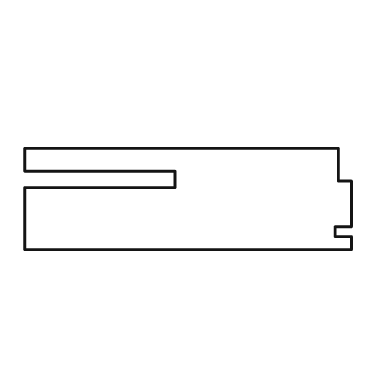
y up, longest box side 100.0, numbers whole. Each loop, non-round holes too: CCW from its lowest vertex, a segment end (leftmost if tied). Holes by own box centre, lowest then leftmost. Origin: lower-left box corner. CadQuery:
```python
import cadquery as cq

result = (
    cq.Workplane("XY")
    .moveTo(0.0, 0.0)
    .lineTo(100.0, 0.0)
    .lineTo(100.0, 4.0)
    .lineTo(95.0, 4.0)
    .lineTo(95.0, 7.0)
    .lineTo(100.0, 7.0)
    .lineTo(100.0, 21.0)
    .lineTo(96.0, 21.0)
    .lineTo(96.0, 31.0)
    .lineTo(0.0, 31.0)
    .lineTo(0.0, 24.0)
    .lineTo(46.0, 24.0)
    .lineTo(46.0, 19.0)
    .lineTo(0.0, 19.0)
    .close()
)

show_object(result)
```